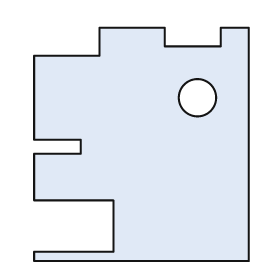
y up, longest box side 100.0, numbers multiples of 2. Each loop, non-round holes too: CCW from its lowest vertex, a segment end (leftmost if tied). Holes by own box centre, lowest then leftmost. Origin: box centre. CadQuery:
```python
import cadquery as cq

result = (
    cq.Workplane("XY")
    .moveTo(-46.0, -50.0)
    .lineTo(46.0, -50.0)
    .lineTo(46.0, 50.0)
    .lineTo(34.0, 50.0)
    .lineTo(34.0, 42.0)
    .lineTo(10.0, 42.0)
    .lineTo(10.0, 50.0)
    .lineTo(-18.0, 50.0)
    .lineTo(-18.0, 38.0)
    .lineTo(-46.0, 38.0)
    .lineTo(-46.0, 2.0)
    .lineTo(-26.0, 2.0)
    .lineTo(-26.0, -4.0)
    .lineTo(-46.0, -4.0)
    .lineTo(-46.0, -24.0)
    .lineTo(-12.0, -24.0)
    .lineTo(-12.0, -46.0)
    .lineTo(-46.0, -46.0)
    .close()
    .moveTo(24.0, 20.0)
    .circle(8.0)
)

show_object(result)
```